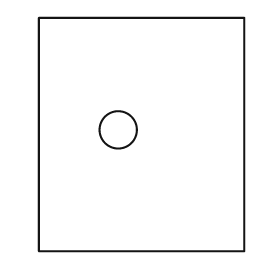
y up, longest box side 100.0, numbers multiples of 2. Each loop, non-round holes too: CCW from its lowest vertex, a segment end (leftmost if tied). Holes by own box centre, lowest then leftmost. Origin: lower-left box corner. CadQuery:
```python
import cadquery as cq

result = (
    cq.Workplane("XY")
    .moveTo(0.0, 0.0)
    .lineTo(88.0, 0.0)
    .lineTo(88.0, 100.0)
    .lineTo(0.0, 100.0)
    .close()
    .moveTo(34.0, 52.0)
    .circle(8.0)
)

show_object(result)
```